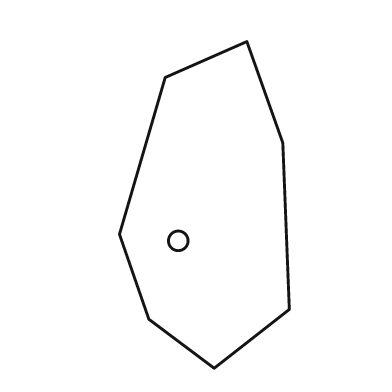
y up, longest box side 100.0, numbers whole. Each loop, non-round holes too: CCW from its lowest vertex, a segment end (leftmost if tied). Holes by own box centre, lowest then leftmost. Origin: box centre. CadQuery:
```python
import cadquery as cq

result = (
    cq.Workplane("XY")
    .moveTo(3.0, -50.0)
    .lineTo(26.0, -32.0)
    .lineTo(24.0, 19.0)
    .lineTo(13.0, 50.0)
    .lineTo(-12.0, 39.0)
    .lineTo(-26.0, -9.0)
    .lineTo(-17.0, -35.0)
    .close()
    .moveTo(-8.0, -11.0)
    .circle(3.0)
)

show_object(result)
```